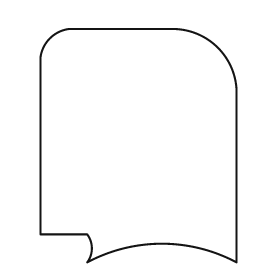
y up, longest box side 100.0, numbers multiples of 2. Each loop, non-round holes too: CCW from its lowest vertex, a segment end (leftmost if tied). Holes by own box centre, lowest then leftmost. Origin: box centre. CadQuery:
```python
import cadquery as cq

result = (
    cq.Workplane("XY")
    .moveTo(-22.0, -50.0)
    .threePointArc((10.0, -42.0), (42.0, -50.0))
    .lineTo(42.0, 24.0)
    .threePointArc((34.0, 42.0), (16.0, 50.0))
    .lineTo(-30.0, 50.0)
    .threePointArc((-38.0, 46.0), (-42.0, 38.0))
    .lineTo(-42.0, -38.0)
    .lineTo(-22.0, -38.0)
    .threePointArc((-20.0, -44.0), (-22.0, -50.0))
    .close()
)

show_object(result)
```